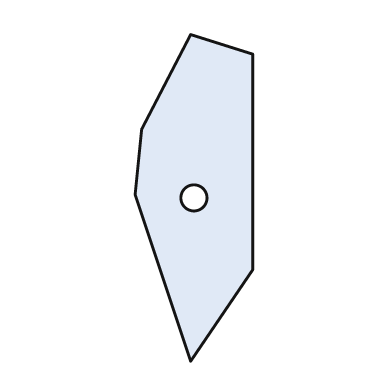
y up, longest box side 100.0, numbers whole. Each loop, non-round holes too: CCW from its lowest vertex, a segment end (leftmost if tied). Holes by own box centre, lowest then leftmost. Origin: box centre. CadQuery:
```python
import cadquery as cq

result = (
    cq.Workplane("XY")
    .moveTo(-1.0, -50.0)
    .lineTo(18.0, -22.0)
    .lineTo(18.0, 44.0)
    .lineTo(-1.0, 50.0)
    .lineTo(-16.0, 21.0)
    .lineTo(-18.0, 1.0)
    .close()
    .moveTo(0.0, 0.0)
    .circle(4.0)
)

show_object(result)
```